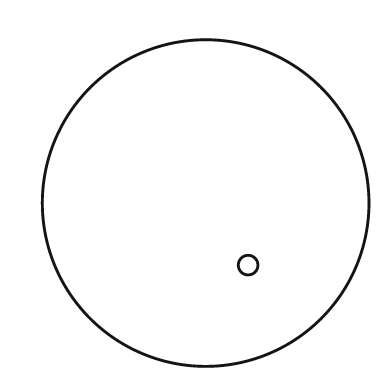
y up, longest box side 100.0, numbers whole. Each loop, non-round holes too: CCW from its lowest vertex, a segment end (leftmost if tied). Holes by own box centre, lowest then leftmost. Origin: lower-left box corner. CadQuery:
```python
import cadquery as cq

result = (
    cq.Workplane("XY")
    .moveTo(50.0, 50.0)
    .circle(50.0)
    .moveTo(63.0, 31.0)
    .circle(3.0)
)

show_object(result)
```